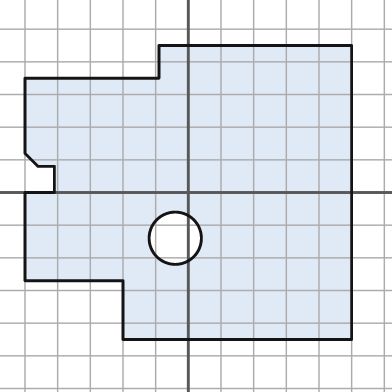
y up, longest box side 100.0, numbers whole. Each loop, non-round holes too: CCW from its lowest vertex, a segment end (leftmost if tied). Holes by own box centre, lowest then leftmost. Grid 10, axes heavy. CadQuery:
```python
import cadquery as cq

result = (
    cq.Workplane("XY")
    .moveTo(-20.0, -45.0)
    .lineTo(50.0, -45.0)
    .lineTo(50.0, 45.0)
    .lineTo(-9.0, 45.0)
    .lineTo(-9.0, 35.0)
    .lineTo(-50.0, 35.0)
    .lineTo(-50.0, 12.0)
    .lineTo(-46.0, 8.0)
    .lineTo(-41.0, 8.0)
    .lineTo(-41.0, 0.0)
    .lineTo(-50.0, 0.0)
    .lineTo(-50.0, -27.0)
    .lineTo(-20.0, -27.0)
    .close()
    .moveTo(-4.0, -14.0)
    .circle(8.0)
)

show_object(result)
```